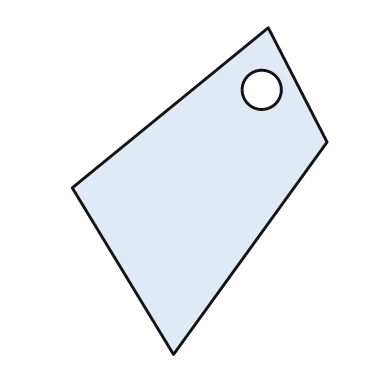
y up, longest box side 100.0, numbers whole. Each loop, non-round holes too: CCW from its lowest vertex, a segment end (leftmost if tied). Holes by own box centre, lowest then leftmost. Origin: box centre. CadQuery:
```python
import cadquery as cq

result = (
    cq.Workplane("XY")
    .moveTo(-8.0, -50.0)
    .lineTo(39.0, 15.0)
    .lineTo(21.0, 50.0)
    .lineTo(-39.0, 1.0)
    .close()
    .moveTo(19.0, 31.0)
    .circle(6.0)
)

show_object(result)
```